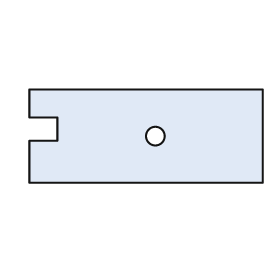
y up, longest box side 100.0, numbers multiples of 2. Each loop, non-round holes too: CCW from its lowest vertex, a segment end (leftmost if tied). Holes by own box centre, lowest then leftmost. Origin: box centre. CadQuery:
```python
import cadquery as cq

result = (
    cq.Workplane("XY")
    .moveTo(-50.0, -20.0)
    .lineTo(50.0, -20.0)
    .lineTo(50.0, 20.0)
    .lineTo(-50.0, 20.0)
    .lineTo(-50.0, 8.0)
    .lineTo(-38.0, 8.0)
    .lineTo(-38.0, -2.0)
    .lineTo(-50.0, -2.0)
    .close()
    .moveTo(4.0, 0.0)
    .circle(4.0)
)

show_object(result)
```